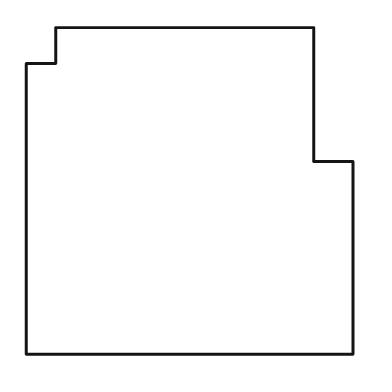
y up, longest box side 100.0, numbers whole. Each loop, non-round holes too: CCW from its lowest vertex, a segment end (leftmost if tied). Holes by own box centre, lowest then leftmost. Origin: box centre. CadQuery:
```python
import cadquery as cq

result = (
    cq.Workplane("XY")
    .moveTo(-50.0, -50.0)
    .lineTo(50.0, -50.0)
    .lineTo(50.0, 9.0)
    .lineTo(38.0, 9.0)
    .lineTo(38.0, 50.0)
    .lineTo(-41.0, 50.0)
    .lineTo(-41.0, 39.0)
    .lineTo(-50.0, 39.0)
    .close()
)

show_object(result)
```